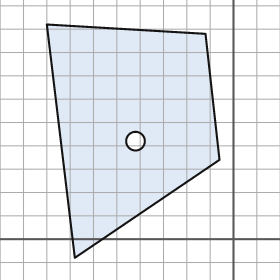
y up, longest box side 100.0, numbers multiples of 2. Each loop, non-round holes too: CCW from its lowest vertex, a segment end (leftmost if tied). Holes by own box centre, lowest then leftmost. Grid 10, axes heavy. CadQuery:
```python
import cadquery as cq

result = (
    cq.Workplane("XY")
    .moveTo(-68.0, -8.0)
    .lineTo(-6.0, 34.0)
    .lineTo(-12.0, 88.0)
    .lineTo(-80.0, 92.0)
    .close()
    .moveTo(-42.0, 42.0)
    .circle(4.0)
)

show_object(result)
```